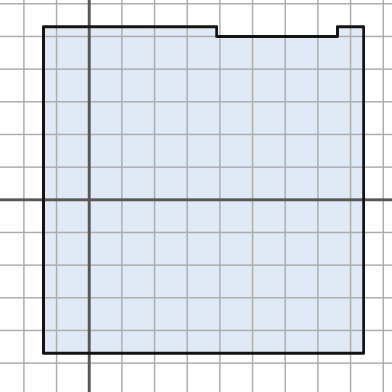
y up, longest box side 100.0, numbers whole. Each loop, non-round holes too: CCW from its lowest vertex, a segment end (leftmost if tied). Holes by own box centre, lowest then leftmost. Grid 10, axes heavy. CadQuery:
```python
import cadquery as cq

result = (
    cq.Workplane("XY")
    .moveTo(-14.0, -47.0)
    .lineTo(84.0, -47.0)
    .lineTo(84.0, 53.0)
    .lineTo(76.0, 53.0)
    .lineTo(76.0, 50.0)
    .lineTo(39.0, 50.0)
    .lineTo(39.0, 53.0)
    .lineTo(-14.0, 53.0)
    .close()
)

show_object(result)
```